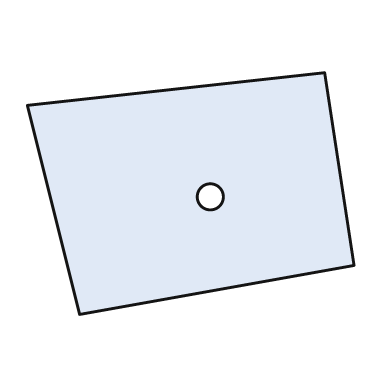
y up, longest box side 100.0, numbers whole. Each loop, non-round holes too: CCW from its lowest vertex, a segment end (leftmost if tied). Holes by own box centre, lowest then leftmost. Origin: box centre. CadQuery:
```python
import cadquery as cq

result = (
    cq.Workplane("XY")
    .moveTo(-34.0, -37.0)
    .lineTo(50.0, -22.0)
    .lineTo(41.0, 37.0)
    .lineTo(-50.0, 27.0)
    .close()
    .moveTo(6.0, -1.0)
    .circle(4.0)
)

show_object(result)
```